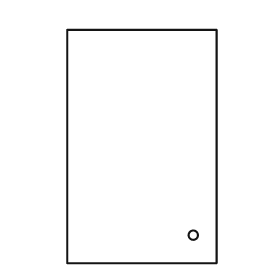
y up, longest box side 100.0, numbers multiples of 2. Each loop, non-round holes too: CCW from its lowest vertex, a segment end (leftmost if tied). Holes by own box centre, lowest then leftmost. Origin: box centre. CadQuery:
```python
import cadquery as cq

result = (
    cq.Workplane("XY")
    .moveTo(-32.0, -50.0)
    .lineTo(32.0, -50.0)
    .lineTo(32.0, 50.0)
    .lineTo(-32.0, 50.0)
    .close()
    .moveTo(22.0, -38.0)
    .circle(2.0)
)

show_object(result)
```